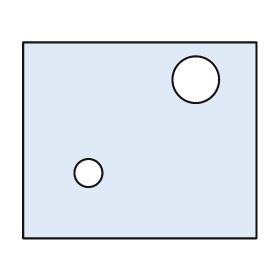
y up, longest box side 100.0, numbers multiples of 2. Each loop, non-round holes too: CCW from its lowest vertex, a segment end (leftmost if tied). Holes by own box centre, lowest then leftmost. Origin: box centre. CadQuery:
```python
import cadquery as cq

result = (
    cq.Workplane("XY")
    .moveTo(-50.0, -42.0)
    .lineTo(50.0, -42.0)
    .lineTo(50.0, 42.0)
    .lineTo(-50.0, 42.0)
    .close()
    .moveTo(-22.0, -14.0)
    .circle(6.0)
    .moveTo(24.0, 26.0)
    .circle(10.0)
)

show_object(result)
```